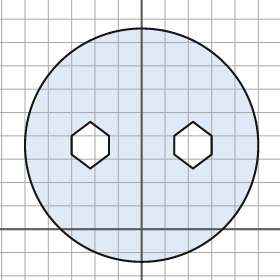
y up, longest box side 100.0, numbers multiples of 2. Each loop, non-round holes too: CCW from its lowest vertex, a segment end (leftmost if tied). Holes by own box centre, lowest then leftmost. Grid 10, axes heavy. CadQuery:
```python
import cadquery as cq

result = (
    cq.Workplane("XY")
    .moveTo(0.0, 36.0)
    .circle(50.0)
    .moveTo(-22.0, 26.0)
    .lineTo(-14.0, 32.0)
    .lineTo(-14.0, 40.0)
    .lineTo(-22.0, 46.0)
    .lineTo(-30.0, 40.0)
    .lineTo(-30.0, 32.0)
    .close()
    .moveTo(22.0, 26.0)
    .lineTo(30.0, 32.0)
    .lineTo(30.0, 40.0)
    .lineTo(22.0, 46.0)
    .lineTo(14.0, 40.0)
    .lineTo(14.0, 32.0)
    .close()
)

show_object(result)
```